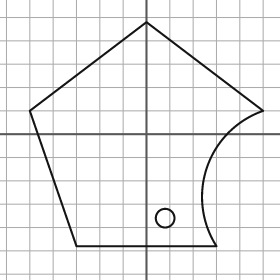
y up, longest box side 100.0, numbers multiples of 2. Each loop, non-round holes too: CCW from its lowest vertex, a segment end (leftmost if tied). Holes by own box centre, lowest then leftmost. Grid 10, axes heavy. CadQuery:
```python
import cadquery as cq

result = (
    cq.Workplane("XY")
    .moveTo(-30.0, -48.0)
    .lineTo(30.0, -48.0)
    .threePointArc((26.0, -14.0), (50.0, 10.0))
    .lineTo(0.0, 48.0)
    .lineTo(-50.0, 10.0)
    .close()
    .moveTo(8.0, -36.0)
    .circle(4.0)
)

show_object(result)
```